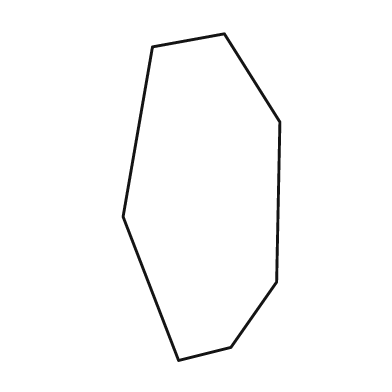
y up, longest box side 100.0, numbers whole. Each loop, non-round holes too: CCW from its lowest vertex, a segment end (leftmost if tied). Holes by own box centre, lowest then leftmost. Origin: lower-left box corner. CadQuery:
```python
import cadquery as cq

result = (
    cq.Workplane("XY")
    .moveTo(17.0, 0.0)
    .lineTo(33.0, 4.0)
    .lineTo(47.0, 24.0)
    .lineTo(48.0, 73.0)
    .lineTo(31.0, 100.0)
    .lineTo(9.0, 96.0)
    .lineTo(0.0, 44.0)
    .close()
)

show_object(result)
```